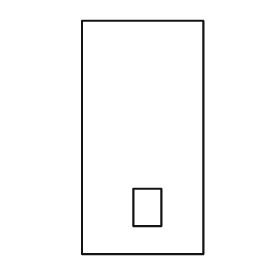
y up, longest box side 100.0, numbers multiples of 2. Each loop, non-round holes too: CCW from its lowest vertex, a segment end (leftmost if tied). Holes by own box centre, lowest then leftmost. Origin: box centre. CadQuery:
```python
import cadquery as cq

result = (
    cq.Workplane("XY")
    .moveTo(-26.0, -50.0)
    .lineTo(26.0, -50.0)
    .lineTo(26.0, 50.0)
    .lineTo(-26.0, 50.0)
    .close()
    .moveTo(-4.0, -38.0)
    .lineTo(8.0, -38.0)
    .lineTo(8.0, -22.0)
    .lineTo(-4.0, -22.0)
    .close()
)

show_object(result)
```